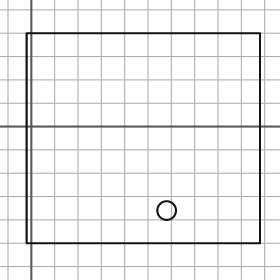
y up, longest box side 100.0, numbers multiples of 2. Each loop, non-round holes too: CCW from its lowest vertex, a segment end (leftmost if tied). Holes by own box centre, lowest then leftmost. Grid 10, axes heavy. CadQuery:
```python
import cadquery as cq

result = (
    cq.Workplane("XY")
    .moveTo(-2.0, -50.0)
    .lineTo(98.0, -50.0)
    .lineTo(98.0, 40.0)
    .lineTo(-2.0, 40.0)
    .close()
    .moveTo(58.0, -36.0)
    .circle(4.0)
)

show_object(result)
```